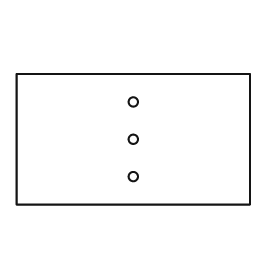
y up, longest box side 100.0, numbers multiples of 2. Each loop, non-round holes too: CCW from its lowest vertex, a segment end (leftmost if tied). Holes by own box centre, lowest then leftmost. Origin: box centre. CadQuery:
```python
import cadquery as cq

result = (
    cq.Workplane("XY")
    .moveTo(-50.0, -28.0)
    .lineTo(50.0, -28.0)
    .lineTo(50.0, 28.0)
    .lineTo(-50.0, 28.0)
    .close()
    .moveTo(0.0, -16.0)
    .circle(2.0)
    .moveTo(0.0, 0.0)
    .circle(2.0)
    .moveTo(0.0, 16.0)
    .circle(2.0)
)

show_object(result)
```